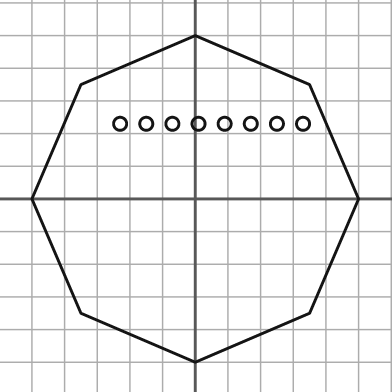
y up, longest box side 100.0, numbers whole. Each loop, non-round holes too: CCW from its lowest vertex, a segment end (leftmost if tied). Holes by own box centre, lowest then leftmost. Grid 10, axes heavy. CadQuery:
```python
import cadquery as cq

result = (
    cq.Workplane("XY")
    .moveTo(0.0, -50.0)
    .lineTo(35.0, -35.0)
    .lineTo(50.0, 0.0)
    .lineTo(35.0, 35.0)
    .lineTo(0.0, 50.0)
    .lineTo(-35.0, 35.0)
    .lineTo(-50.0, 0.0)
    .lineTo(-35.0, -35.0)
    .close()
    .moveTo(-23.0, 23.0)
    .circle(2.0)
    .moveTo(-15.0, 23.0)
    .circle(2.0)
    .moveTo(-7.0, 23.0)
    .circle(2.0)
    .moveTo(1.0, 23.0)
    .circle(2.0)
    .moveTo(9.0, 23.0)
    .circle(2.0)
    .moveTo(17.0, 23.0)
    .circle(2.0)
    .moveTo(25.0, 23.0)
    .circle(2.0)
    .moveTo(33.0, 23.0)
    .circle(2.0)
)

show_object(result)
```